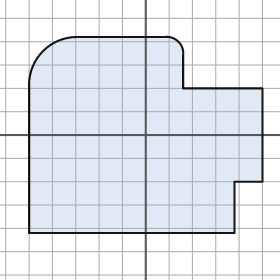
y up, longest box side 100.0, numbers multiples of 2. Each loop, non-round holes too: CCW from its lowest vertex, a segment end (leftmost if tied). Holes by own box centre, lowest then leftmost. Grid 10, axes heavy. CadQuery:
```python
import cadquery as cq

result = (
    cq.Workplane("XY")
    .moveTo(-50.0, -42.0)
    .lineTo(38.0, -42.0)
    .lineTo(38.0, -20.0)
    .lineTo(50.0, -20.0)
    .lineTo(50.0, 20.0)
    .lineTo(16.0, 20.0)
    .lineTo(16.0, 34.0)
    .threePointArc((14.0, 40.0), (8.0, 42.0))
    .lineTo(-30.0, 42.0)
    .threePointArc((-44.0, 36.0), (-50.0, 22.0))
    .close()
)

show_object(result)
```